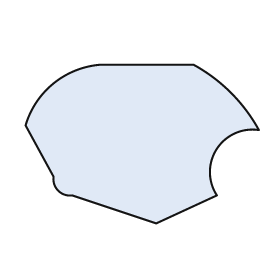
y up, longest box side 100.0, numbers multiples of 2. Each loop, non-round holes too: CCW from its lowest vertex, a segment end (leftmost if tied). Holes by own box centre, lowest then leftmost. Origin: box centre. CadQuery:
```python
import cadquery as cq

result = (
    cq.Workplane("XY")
    .moveTo(6.0, -34.0)
    .lineTo(32.0, -22.0)
    .threePointArc((32.0, -2.0), (50.0, 6.0))
    .threePointArc((38.0, 22.0), (22.0, 34.0))
    .lineTo(-18.0, 34.0)
    .threePointArc((-38.0, 26.0), (-50.0, 8.0))
    .lineTo(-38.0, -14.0)
    .threePointArc((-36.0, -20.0), (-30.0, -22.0))
    .close()
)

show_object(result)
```